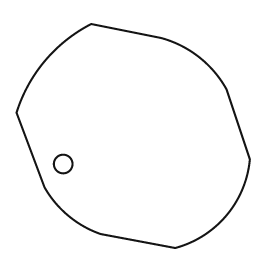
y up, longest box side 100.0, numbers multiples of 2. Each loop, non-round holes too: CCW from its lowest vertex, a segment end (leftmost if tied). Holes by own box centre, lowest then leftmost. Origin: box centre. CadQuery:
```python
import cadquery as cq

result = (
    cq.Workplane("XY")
    .moveTo(18.0, -48.0)
    .threePointArc((40.0, -34.0), (50.0, -10.0))
    .lineTo(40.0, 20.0)
    .threePointArc((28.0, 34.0), (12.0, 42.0))
    .lineTo(-18.0, 48.0)
    .threePointArc((-38.0, 32.0), (-50.0, 10.0))
    .lineTo(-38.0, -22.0)
    .threePointArc((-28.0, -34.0), (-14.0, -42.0))
    .close()
    .moveTo(-30.0, -12.0)
    .circle(4.0)
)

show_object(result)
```